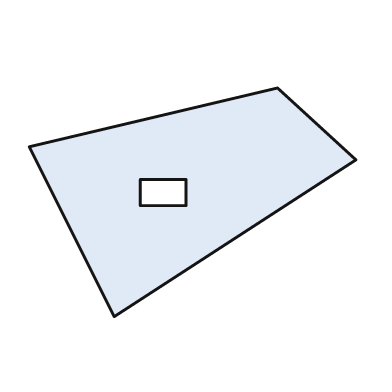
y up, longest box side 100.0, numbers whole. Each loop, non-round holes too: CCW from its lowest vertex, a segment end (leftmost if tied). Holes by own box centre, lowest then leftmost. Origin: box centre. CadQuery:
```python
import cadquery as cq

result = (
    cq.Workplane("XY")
    .moveTo(-24.0, -35.0)
    .lineTo(50.0, 13.0)
    .lineTo(26.0, 35.0)
    .lineTo(-50.0, 17.0)
    .close()
    .moveTo(-16.0, -1.0)
    .lineTo(-2.0, -1.0)
    .lineTo(-2.0, 7.0)
    .lineTo(-16.0, 7.0)
    .close()
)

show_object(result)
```